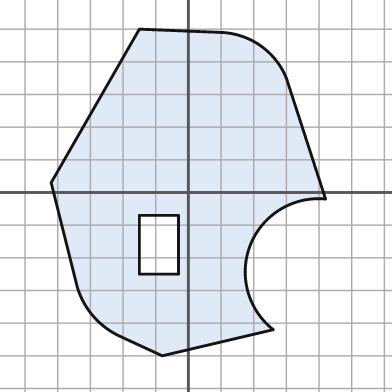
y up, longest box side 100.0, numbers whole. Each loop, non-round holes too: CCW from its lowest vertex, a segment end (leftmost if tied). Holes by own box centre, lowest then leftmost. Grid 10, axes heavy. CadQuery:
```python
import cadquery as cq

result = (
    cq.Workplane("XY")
    .moveTo(-8.0, -50.0)
    .lineTo(26.0, -42.0)
    .threePointArc((19.0, -16.0), (42.0, -2.0))
    .lineTo(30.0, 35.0)
    .threePointArc((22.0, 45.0), (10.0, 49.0))
    .lineTo(-15.0, 50.0)
    .lineTo(-42.0, 3.0)
    .lineTo(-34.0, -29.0)
    .threePointArc((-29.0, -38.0), (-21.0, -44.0))
    .close()
    .moveTo(-15.0, -25.0)
    .lineTo(-3.0, -25.0)
    .lineTo(-3.0, -7.0)
    .lineTo(-15.0, -7.0)
    .close()
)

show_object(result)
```